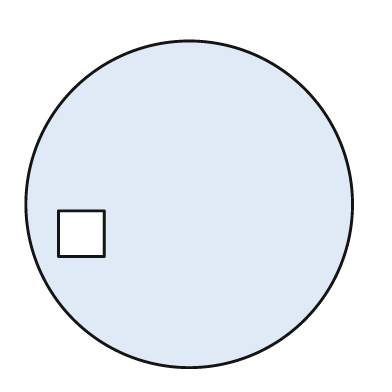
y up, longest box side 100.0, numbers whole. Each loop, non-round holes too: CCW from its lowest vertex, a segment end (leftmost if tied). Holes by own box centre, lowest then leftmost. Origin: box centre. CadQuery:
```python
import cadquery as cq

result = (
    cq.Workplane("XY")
    .moveTo(0.0, 0.0)
    .circle(50.0)
    .moveTo(-40.0, -16.0)
    .lineTo(-26.0, -16.0)
    .lineTo(-26.0, -2.0)
    .lineTo(-40.0, -2.0)
    .close()
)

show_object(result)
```